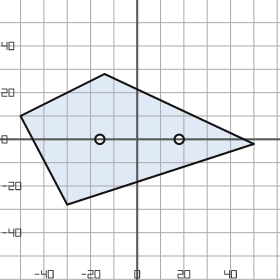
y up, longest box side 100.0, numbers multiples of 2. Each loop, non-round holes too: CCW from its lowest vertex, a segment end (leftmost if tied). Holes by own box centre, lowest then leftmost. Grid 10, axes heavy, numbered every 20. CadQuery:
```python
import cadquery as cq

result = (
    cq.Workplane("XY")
    .moveTo(-30.0, -28.0)
    .lineTo(50.0, -2.0)
    .lineTo(-14.0, 28.0)
    .lineTo(-50.0, 10.0)
    .close()
    .moveTo(-16.0, 0.0)
    .circle(2.0)
    .moveTo(18.0, 0.0)
    .circle(2.0)
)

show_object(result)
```